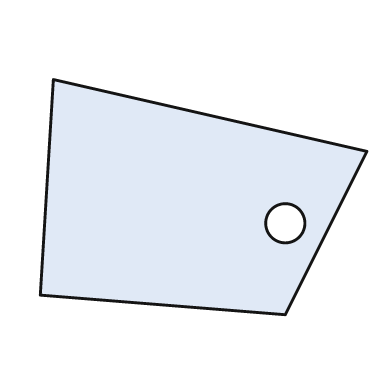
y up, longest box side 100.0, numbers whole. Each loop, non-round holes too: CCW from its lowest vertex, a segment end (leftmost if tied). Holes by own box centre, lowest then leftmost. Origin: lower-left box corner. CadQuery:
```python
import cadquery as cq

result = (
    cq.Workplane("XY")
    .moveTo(75.0, 0.0)
    .lineTo(100.0, 50.0)
    .lineTo(4.0, 72.0)
    .lineTo(0.0, 6.0)
    .close()
    .moveTo(75.0, 28.0)
    .circle(6.0)
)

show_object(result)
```